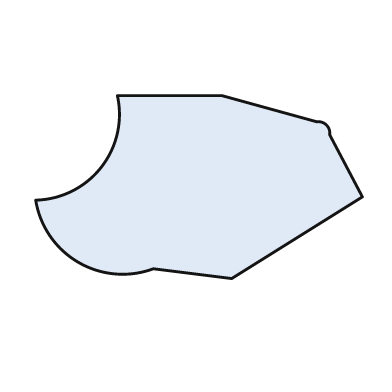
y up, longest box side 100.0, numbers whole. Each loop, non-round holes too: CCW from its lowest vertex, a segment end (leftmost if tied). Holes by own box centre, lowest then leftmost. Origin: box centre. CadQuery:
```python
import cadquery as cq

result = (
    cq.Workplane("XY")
    .moveTo(10.0, -28.0)
    .lineTo(50.0, -3.0)
    .lineTo(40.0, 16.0)
    .threePointArc((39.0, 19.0), (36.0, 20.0))
    .lineTo(7.0, 28.0)
    .lineTo(-25.0, 28.0)
    .threePointArc((-30.0, 6.0), (-50.0, -4.0))
    .threePointArc((-37.0, -23.0), (-14.0, -25.0))
    .close()
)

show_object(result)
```